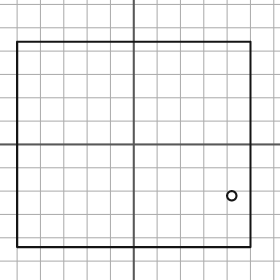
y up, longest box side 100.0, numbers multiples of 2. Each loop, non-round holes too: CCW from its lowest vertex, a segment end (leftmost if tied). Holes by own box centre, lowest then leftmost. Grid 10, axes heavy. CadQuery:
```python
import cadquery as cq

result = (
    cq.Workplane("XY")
    .moveTo(-50.0, -44.0)
    .lineTo(50.0, -44.0)
    .lineTo(50.0, 44.0)
    .lineTo(-50.0, 44.0)
    .close()
    .moveTo(42.0, -22.0)
    .circle(2.0)
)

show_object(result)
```